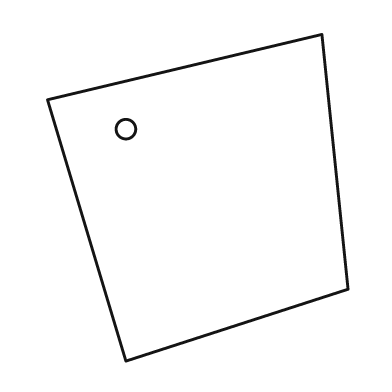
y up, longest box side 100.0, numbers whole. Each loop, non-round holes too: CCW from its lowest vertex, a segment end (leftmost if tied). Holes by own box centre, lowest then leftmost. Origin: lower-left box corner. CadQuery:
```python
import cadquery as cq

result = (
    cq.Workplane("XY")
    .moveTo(24.0, 0.0)
    .lineTo(92.0, 22.0)
    .lineTo(84.0, 100.0)
    .lineTo(0.0, 80.0)
    .close()
    .moveTo(24.0, 71.0)
    .circle(3.0)
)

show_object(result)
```